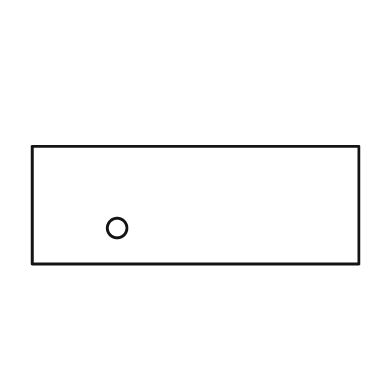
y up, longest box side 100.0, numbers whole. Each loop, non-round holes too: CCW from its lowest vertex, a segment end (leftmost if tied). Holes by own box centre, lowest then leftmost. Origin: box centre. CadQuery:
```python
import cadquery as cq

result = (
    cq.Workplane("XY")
    .moveTo(-50.0, -18.0)
    .lineTo(50.0, -18.0)
    .lineTo(50.0, 18.0)
    .lineTo(-50.0, 18.0)
    .close()
    .moveTo(-24.0, -7.0)
    .circle(3.0)
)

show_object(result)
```